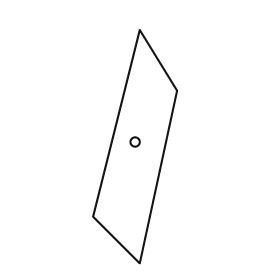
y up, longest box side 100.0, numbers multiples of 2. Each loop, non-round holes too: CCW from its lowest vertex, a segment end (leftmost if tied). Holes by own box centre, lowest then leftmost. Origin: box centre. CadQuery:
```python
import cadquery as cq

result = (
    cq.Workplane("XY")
    .moveTo(2.0, -50.0)
    .lineTo(18.0, 24.0)
    .lineTo(2.0, 50.0)
    .lineTo(-18.0, -30.0)
    .close()
    .moveTo(0.0, 2.0)
    .circle(2.0)
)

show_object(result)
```